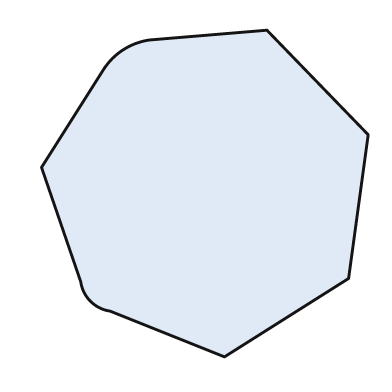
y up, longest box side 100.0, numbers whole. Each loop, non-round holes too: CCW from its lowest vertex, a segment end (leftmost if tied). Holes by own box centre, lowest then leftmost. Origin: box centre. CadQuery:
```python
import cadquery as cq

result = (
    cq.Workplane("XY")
    .moveTo(6.0, -50.0)
    .lineTo(44.0, -26.0)
    .lineTo(50.0, 18.0)
    .lineTo(19.0, 50.0)
    .lineTo(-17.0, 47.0)
    .threePointArc((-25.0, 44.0), (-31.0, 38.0))
    .lineTo(-50.0, 8.0)
    .lineTo(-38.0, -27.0)
    .threePointArc((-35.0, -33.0), (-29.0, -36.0))
    .close()
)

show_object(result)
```